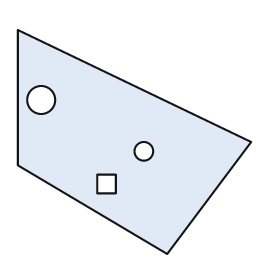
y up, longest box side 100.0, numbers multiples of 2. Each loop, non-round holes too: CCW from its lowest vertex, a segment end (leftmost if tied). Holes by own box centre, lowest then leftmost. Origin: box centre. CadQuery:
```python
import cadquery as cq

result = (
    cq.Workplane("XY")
    .moveTo(14.0, -48.0)
    .lineTo(50.0, 0.0)
    .lineTo(-50.0, 48.0)
    .lineTo(-50.0, -10.0)
    .close()
    .moveTo(-16.0, -22.0)
    .lineTo(-8.0, -22.0)
    .lineTo(-8.0, -14.0)
    .lineTo(-16.0, -14.0)
    .close()
    .moveTo(4.0, -4.0)
    .circle(4.0)
    .moveTo(-40.0, 18.0)
    .circle(6.0)
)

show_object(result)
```